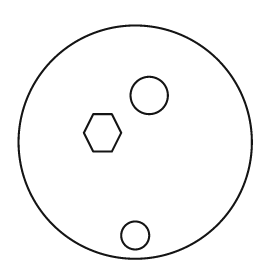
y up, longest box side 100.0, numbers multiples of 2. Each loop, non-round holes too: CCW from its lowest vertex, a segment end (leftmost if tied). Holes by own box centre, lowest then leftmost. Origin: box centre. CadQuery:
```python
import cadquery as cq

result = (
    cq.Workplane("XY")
    .moveTo(0.0, 0.0)
    .circle(50.0)
    .moveTo(0.0, -40.0)
    .circle(6.0)
    .moveTo(-18.0, -4.0)
    .lineTo(-10.0, -4.0)
    .lineTo(-6.0, 4.0)
    .lineTo(-10.0, 12.0)
    .lineTo(-18.0, 12.0)
    .lineTo(-22.0, 4.0)
    .close()
    .moveTo(6.0, 20.0)
    .circle(8.0)
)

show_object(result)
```